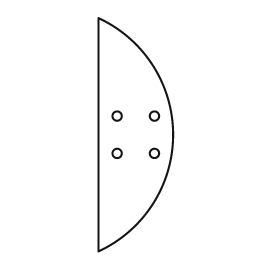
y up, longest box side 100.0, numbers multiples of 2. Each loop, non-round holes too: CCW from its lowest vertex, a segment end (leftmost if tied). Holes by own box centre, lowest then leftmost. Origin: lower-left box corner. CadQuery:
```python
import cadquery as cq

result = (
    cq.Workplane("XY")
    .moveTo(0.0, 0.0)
    .threePointArc((32.0, 50.0), (0.0, 100.0))
    .close()
    .moveTo(8.0, 42.0)
    .circle(2.0)
    .moveTo(24.0, 42.0)
    .circle(2.0)
    .moveTo(8.0, 58.0)
    .circle(2.0)
    .moveTo(24.0, 58.0)
    .circle(2.0)
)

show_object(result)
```